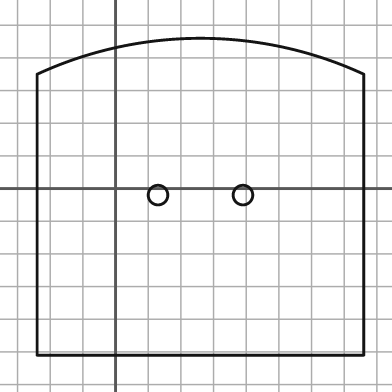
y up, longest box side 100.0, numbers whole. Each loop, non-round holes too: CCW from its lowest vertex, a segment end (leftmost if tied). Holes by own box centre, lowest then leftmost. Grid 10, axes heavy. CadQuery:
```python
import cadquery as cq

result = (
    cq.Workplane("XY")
    .moveTo(-24.0, -51.0)
    .lineTo(76.0, -51.0)
    .lineTo(76.0, 35.0)
    .threePointArc((26.0, 46.0), (-24.0, 35.0))
    .close()
    .moveTo(13.0, -2.0)
    .circle(3.0)
    .moveTo(39.0, -2.0)
    .circle(3.0)
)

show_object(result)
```